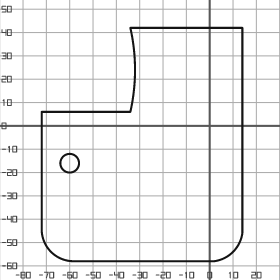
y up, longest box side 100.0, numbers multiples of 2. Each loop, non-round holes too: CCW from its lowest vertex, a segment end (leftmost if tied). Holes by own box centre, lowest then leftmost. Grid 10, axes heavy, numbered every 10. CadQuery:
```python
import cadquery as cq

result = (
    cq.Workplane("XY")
    .moveTo(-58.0, -58.0)
    .lineTo(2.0, -58.0)
    .threePointArc((10.0, -54.0), (14.0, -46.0))
    .lineTo(14.0, 42.0)
    .lineTo(-34.0, 42.0)
    .threePointArc((-32.0, 24.0), (-34.0, 6.0))
    .lineTo(-72.0, 6.0)
    .lineTo(-72.0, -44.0)
    .threePointArc((-68.0, -54.0), (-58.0, -58.0))
    .close()
    .moveTo(-60.0, -16.0)
    .circle(4.0)
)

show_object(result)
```